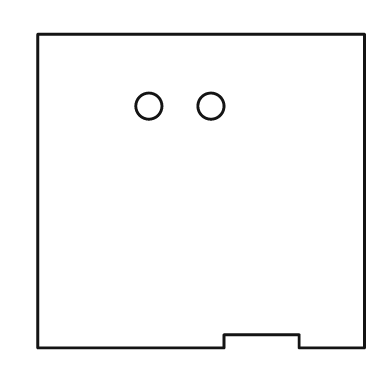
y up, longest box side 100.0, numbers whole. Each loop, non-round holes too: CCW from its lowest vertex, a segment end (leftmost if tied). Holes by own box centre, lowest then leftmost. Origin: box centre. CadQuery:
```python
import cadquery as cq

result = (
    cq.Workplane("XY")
    .moveTo(-50.0, -48.0)
    .lineTo(7.0, -48.0)
    .lineTo(7.0, -44.0)
    .lineTo(30.0, -44.0)
    .lineTo(30.0, -48.0)
    .lineTo(50.0, -48.0)
    .lineTo(50.0, 48.0)
    .lineTo(-50.0, 48.0)
    .close()
    .moveTo(-16.0, 26.0)
    .circle(4.0)
    .moveTo(3.0, 26.0)
    .circle(4.0)
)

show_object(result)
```